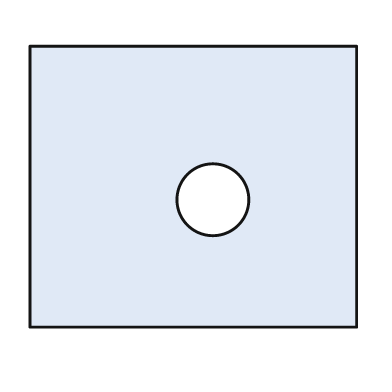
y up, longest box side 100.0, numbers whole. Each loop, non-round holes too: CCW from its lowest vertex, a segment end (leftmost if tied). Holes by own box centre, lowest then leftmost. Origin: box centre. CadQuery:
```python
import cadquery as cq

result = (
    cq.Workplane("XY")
    .moveTo(-50.0, -43.0)
    .lineTo(50.0, -43.0)
    .lineTo(50.0, 43.0)
    .lineTo(-50.0, 43.0)
    .close()
    .moveTo(6.0, -4.0)
    .circle(11.0)
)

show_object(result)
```